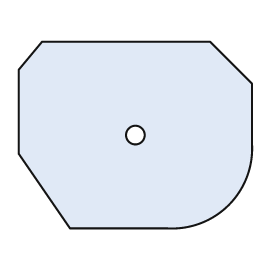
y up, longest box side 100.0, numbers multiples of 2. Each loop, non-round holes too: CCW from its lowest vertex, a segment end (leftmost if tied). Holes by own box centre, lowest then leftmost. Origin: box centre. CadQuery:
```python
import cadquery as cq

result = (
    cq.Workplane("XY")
    .moveTo(-28.0, -40.0)
    .lineTo(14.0, -40.0)
    .threePointArc((40.0, -30.0), (50.0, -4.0))
    .lineTo(50.0, 22.0)
    .lineTo(32.0, 40.0)
    .lineTo(-40.0, 40.0)
    .lineTo(-50.0, 28.0)
    .lineTo(-50.0, -8.0)
    .close()
    .moveTo(0.0, 0.0)
    .circle(4.0)
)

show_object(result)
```